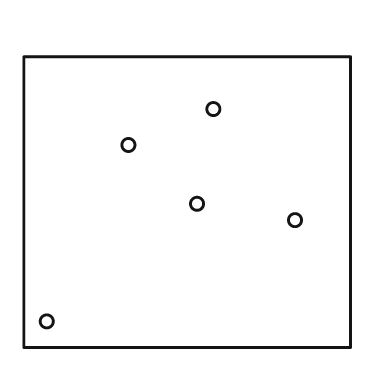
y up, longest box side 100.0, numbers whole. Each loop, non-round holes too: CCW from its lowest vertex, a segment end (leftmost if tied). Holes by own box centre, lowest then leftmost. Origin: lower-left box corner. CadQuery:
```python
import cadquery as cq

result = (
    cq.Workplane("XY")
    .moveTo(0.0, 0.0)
    .lineTo(100.0, 0.0)
    .lineTo(100.0, 89.0)
    .lineTo(0.0, 89.0)
    .close()
    .moveTo(7.0, 8.0)
    .circle(2.0)
    .moveTo(83.0, 39.0)
    .circle(2.0)
    .moveTo(53.0, 44.0)
    .circle(2.0)
    .moveTo(32.0, 62.0)
    .circle(2.0)
    .moveTo(58.0, 73.0)
    .circle(2.0)
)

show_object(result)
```